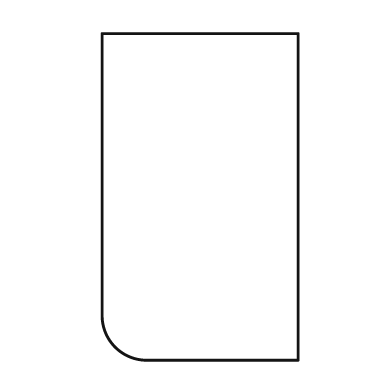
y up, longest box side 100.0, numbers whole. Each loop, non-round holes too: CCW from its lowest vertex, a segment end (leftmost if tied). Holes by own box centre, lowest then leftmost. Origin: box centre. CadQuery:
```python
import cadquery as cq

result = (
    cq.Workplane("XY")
    .moveTo(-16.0, -50.0)
    .lineTo(30.0, -50.0)
    .lineTo(30.0, 50.0)
    .lineTo(-30.0, 50.0)
    .lineTo(-30.0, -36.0)
    .threePointArc((-26.0, -46.0), (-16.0, -50.0))
    .close()
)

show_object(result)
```